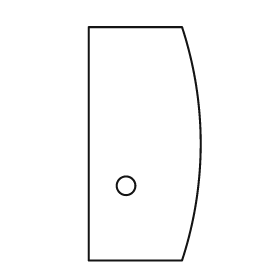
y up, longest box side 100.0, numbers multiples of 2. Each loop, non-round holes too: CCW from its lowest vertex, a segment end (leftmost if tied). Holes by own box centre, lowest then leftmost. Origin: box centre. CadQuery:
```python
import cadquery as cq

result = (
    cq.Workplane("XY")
    .moveTo(-24.0, -50.0)
    .lineTo(16.0, -50.0)
    .threePointArc((24.0, 0.0), (16.0, 50.0))
    .lineTo(-24.0, 50.0)
    .close()
    .moveTo(-8.0, -18.0)
    .circle(4.0)
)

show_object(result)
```